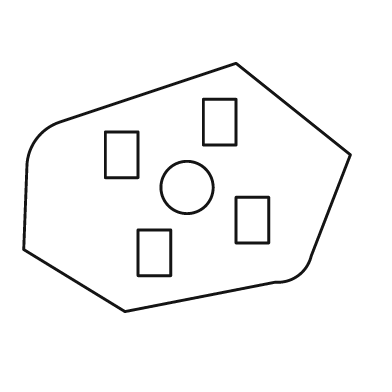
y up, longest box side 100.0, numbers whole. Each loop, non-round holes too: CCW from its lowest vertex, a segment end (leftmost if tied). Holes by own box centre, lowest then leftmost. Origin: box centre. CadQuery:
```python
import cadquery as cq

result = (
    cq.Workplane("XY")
    .moveTo(-19.0, -38.0)
    .lineTo(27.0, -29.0)
    .threePointArc((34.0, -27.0), (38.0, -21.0))
    .lineTo(50.0, 10.0)
    .lineTo(15.0, 38.0)
    .lineTo(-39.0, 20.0)
    .threePointArc((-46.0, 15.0), (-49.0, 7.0))
    .lineTo(-50.0, -19.0)
    .close()
    .moveTo(-15.0, -27.0)
    .lineTo(-5.0, -27.0)
    .lineTo(-5.0, -13.0)
    .lineTo(-15.0, -13.0)
    .close()
    .moveTo(15.0, -17.0)
    .lineTo(25.0, -17.0)
    .lineTo(25.0, -3.0)
    .lineTo(15.0, -3.0)
    .close()
    .moveTo(0.0, 0.0)
    .circle(8.0)
    .moveTo(-25.0, 3.0)
    .lineTo(-15.0, 3.0)
    .lineTo(-15.0, 17.0)
    .lineTo(-25.0, 17.0)
    .close()
    .moveTo(5.0, 13.0)
    .lineTo(15.0, 13.0)
    .lineTo(15.0, 27.0)
    .lineTo(5.0, 27.0)
    .close()
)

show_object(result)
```